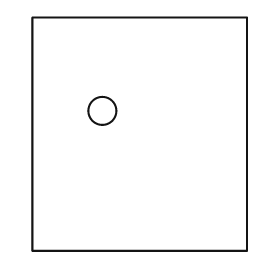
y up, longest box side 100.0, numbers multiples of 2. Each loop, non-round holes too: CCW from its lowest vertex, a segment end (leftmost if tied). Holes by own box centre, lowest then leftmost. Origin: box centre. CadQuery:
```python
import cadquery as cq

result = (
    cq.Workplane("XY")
    .moveTo(-46.0, -50.0)
    .lineTo(46.0, -50.0)
    .lineTo(46.0, 50.0)
    .lineTo(-46.0, 50.0)
    .close()
    .moveTo(-16.0, 10.0)
    .circle(6.0)
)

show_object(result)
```